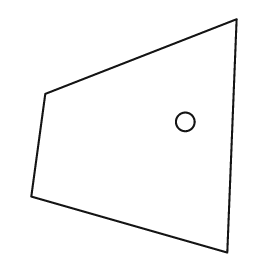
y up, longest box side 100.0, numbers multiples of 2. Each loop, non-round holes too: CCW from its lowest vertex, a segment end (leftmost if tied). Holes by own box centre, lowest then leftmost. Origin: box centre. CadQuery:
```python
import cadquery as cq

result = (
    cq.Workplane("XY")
    .moveTo(40.0, -50.0)
    .lineTo(44.0, 50.0)
    .lineTo(-38.0, 18.0)
    .lineTo(-44.0, -26.0)
    .close()
    .moveTo(22.0, 6.0)
    .circle(4.0)
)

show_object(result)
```